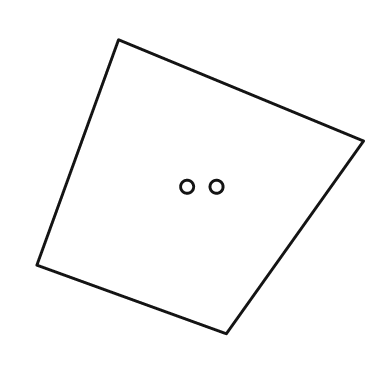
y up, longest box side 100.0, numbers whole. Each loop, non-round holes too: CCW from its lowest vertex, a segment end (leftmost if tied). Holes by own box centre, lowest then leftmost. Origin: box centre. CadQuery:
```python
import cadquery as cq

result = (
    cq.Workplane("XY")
    .moveTo(8.0, -45.0)
    .lineTo(50.0, 14.0)
    .lineTo(-25.0, 45.0)
    .lineTo(-50.0, -24.0)
    .close()
    .moveTo(-4.0, 0.0)
    .circle(2.0)
    .moveTo(5.0, 0.0)
    .circle(2.0)
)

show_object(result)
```